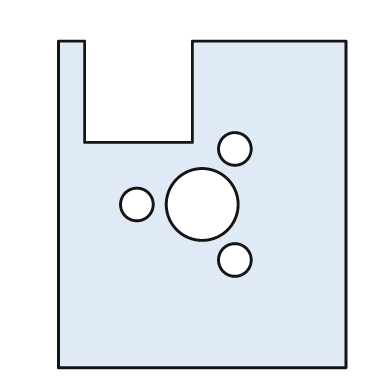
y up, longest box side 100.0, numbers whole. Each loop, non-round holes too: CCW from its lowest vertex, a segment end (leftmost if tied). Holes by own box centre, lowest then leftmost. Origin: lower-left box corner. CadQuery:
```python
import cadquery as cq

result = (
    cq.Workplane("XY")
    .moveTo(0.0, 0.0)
    .lineTo(88.0, 0.0)
    .lineTo(88.0, 100.0)
    .lineTo(41.0, 100.0)
    .lineTo(41.0, 69.0)
    .lineTo(8.0, 69.0)
    .lineTo(8.0, 100.0)
    .lineTo(0.0, 100.0)
    .close()
    .moveTo(54.0, 33.0)
    .circle(5.0)
    .moveTo(24.0, 50.0)
    .circle(5.0)
    .moveTo(44.0, 50.0)
    .circle(11.0)
    .moveTo(54.0, 67.0)
    .circle(5.0)
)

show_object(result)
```